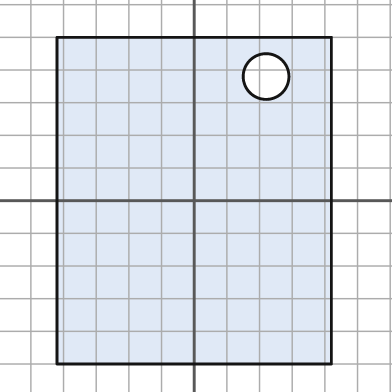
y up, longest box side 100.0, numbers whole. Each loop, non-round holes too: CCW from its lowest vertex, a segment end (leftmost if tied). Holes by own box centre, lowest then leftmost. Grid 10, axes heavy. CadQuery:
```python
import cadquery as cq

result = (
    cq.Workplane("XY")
    .moveTo(-42.0, -50.0)
    .lineTo(42.0, -50.0)
    .lineTo(42.0, 50.0)
    .lineTo(-42.0, 50.0)
    .close()
    .moveTo(22.0, 38.0)
    .circle(7.0)
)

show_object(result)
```